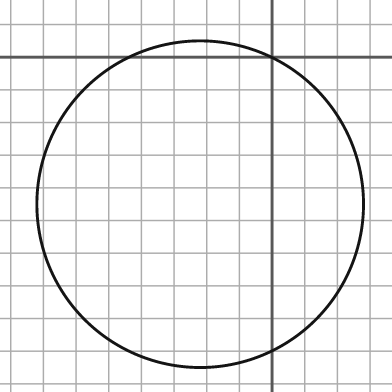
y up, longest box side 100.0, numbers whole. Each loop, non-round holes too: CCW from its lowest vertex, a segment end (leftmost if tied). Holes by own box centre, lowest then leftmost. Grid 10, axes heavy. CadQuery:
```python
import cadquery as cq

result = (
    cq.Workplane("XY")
    .moveTo(-22.0, -45.0)
    .circle(50.0)
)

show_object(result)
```